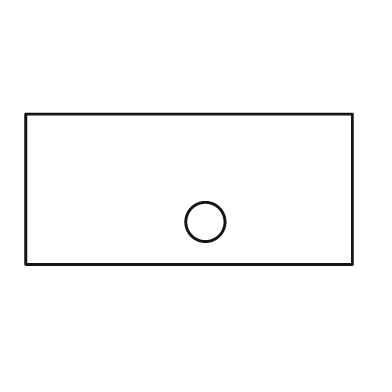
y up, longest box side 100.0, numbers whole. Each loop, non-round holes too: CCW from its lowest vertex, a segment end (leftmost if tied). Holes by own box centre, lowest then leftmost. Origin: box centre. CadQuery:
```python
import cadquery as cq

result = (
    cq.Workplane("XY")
    .moveTo(-50.0, -23.0)
    .lineTo(50.0, -23.0)
    .lineTo(50.0, 23.0)
    .lineTo(-50.0, 23.0)
    .close()
    .moveTo(5.0, -10.0)
    .circle(6.0)
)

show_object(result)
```